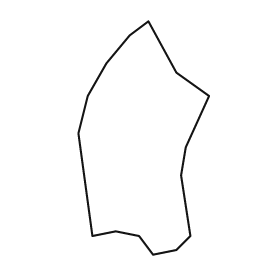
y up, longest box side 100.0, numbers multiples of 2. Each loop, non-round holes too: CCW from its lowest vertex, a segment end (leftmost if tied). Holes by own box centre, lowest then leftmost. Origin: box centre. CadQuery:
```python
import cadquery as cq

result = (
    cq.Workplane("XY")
    .moveTo(4.0, -50.0)
    .lineTo(14.0, -48.0)
    .lineTo(20.0, -42.0)
    .lineTo(16.0, -16.0)
    .lineTo(18.0, -4.0)
    .lineTo(28.0, 18.0)
    .lineTo(14.0, 28.0)
    .lineTo(2.0, 50.0)
    .lineTo(-6.0, 44.0)
    .lineTo(-16.0, 32.0)
    .lineTo(-24.0, 18.0)
    .lineTo(-28.0, 2.0)
    .lineTo(-22.0, -42.0)
    .lineTo(-12.0, -40.0)
    .lineTo(-2.0, -42.0)
    .close()
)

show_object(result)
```